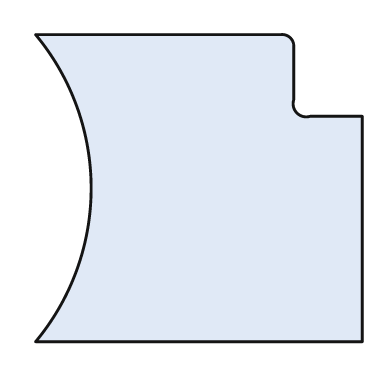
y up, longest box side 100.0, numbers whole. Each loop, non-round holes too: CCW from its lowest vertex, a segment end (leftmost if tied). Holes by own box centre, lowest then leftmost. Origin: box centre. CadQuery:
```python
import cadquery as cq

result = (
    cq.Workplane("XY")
    .moveTo(-50.0, -47.0)
    .lineTo(50.0, -47.0)
    .lineTo(50.0, 22.0)
    .lineTo(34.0, 22.0)
    .threePointArc((30.0, 23.0), (29.0, 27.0))
    .lineTo(29.0, 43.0)
    .threePointArc((28.0, 46.0), (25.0, 47.0))
    .lineTo(-50.0, 47.0)
    .threePointArc((-33.0, 0.0), (-50.0, -47.0))
    .close()
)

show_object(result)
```